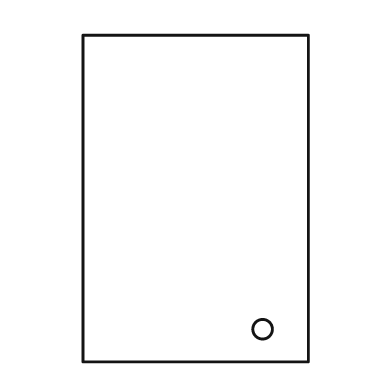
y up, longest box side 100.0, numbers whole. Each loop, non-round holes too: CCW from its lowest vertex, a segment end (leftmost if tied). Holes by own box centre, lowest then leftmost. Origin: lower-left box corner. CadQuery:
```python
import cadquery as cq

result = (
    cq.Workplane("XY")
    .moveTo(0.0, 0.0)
    .lineTo(69.0, 0.0)
    .lineTo(69.0, 100.0)
    .lineTo(0.0, 100.0)
    .close()
    .moveTo(55.0, 10.0)
    .circle(3.0)
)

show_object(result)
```